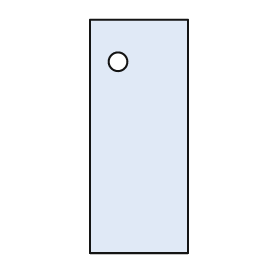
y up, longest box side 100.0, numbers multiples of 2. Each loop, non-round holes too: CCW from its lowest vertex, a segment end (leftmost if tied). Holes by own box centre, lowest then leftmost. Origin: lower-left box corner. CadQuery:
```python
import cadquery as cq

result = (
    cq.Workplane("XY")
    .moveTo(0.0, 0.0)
    .lineTo(42.0, 0.0)
    .lineTo(42.0, 100.0)
    .lineTo(0.0, 100.0)
    .close()
    .moveTo(12.0, 82.0)
    .circle(4.0)
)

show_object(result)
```